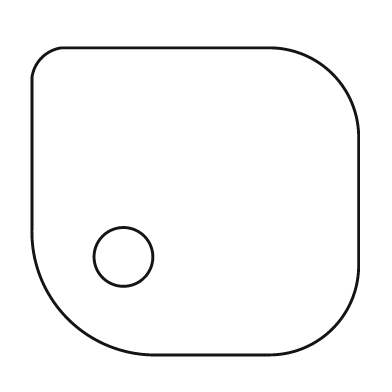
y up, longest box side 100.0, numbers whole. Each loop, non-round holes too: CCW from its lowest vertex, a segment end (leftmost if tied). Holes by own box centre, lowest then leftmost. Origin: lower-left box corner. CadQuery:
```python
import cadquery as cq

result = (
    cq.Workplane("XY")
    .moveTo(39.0, 0.0)
    .lineTo(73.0, 0.0)
    .threePointArc((92.0, 8.0), (100.0, 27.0))
    .lineTo(100.0, 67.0)
    .threePointArc((92.0, 86.0), (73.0, 94.0))
    .lineTo(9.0, 94.0)
    .threePointArc((3.0, 91.0), (0.0, 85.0))
    .lineTo(0.0, 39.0)
    .threePointArc((11.0, 11.0), (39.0, 0.0))
    .close()
    .moveTo(28.0, 30.0)
    .circle(9.0)
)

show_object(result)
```